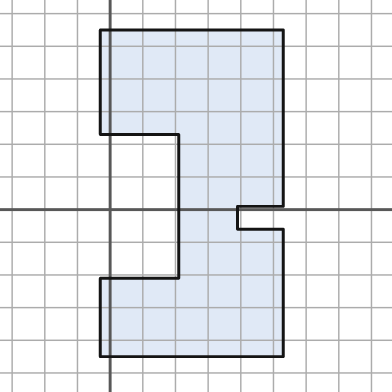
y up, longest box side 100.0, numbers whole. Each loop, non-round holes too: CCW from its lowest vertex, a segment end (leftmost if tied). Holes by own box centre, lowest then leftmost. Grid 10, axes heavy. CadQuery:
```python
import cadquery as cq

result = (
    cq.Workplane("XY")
    .moveTo(-3.0, -45.0)
    .lineTo(53.0, -45.0)
    .lineTo(53.0, -6.0)
    .lineTo(39.0, -6.0)
    .lineTo(39.0, 1.0)
    .lineTo(53.0, 1.0)
    .lineTo(53.0, 55.0)
    .lineTo(-3.0, 55.0)
    .lineTo(-3.0, 23.0)
    .lineTo(21.0, 23.0)
    .lineTo(21.0, -21.0)
    .lineTo(-3.0, -21.0)
    .close()
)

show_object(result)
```